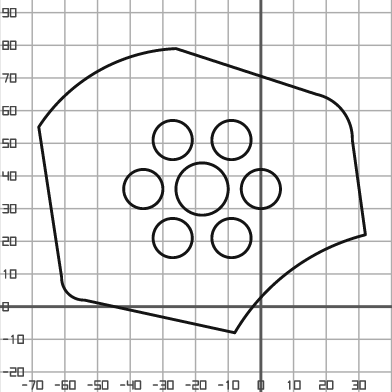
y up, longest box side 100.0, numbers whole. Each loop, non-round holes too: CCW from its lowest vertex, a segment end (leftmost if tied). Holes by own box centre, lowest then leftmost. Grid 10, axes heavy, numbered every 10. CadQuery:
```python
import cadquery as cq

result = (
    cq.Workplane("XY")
    .moveTo(-8.0, -8.0)
    .threePointArc((9.0, 11.0), (32.0, 22.0))
    .lineTo(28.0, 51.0)
    .threePointArc((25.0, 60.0), (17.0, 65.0))
    .lineTo(-26.0, 79.0)
    .threePointArc((-50.0, 72.0), (-68.0, 55.0))
    .lineTo(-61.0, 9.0)
    .threePointArc((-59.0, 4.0), (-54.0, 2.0))
    .close()
    .moveTo(-27.0, 21.0)
    .circle(6.0)
    .moveTo(-9.0, 21.0)
    .circle(6.0)
    .moveTo(-36.0, 36.0)
    .circle(6.0)
    .moveTo(-18.0, 36.0)
    .circle(8.0)
    .moveTo(0.0, 36.0)
    .circle(6.0)
    .moveTo(-27.0, 51.0)
    .circle(6.0)
    .moveTo(-9.0, 51.0)
    .circle(6.0)
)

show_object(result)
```